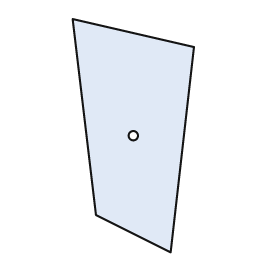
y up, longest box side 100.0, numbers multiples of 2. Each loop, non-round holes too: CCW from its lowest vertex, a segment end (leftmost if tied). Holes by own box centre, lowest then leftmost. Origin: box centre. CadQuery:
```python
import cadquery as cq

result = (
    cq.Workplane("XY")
    .moveTo(16.0, -50.0)
    .lineTo(26.0, 38.0)
    .lineTo(-26.0, 50.0)
    .lineTo(-16.0, -34.0)
    .close()
    .moveTo(0.0, 0.0)
    .circle(2.0)
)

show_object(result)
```